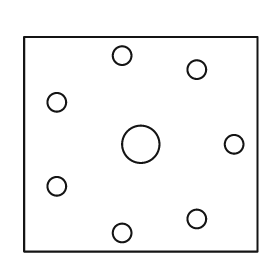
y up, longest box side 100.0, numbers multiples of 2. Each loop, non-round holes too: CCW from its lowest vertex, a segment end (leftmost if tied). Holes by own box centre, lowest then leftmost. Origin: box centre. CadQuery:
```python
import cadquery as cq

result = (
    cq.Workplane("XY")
    .moveTo(-50.0, -46.0)
    .lineTo(50.0, -46.0)
    .lineTo(50.0, 46.0)
    .lineTo(-50.0, 46.0)
    .close()
    .moveTo(-8.0, -38.0)
    .circle(4.0)
    .moveTo(24.0, -32.0)
    .circle(4.0)
    .moveTo(-36.0, -18.0)
    .circle(4.0)
    .moveTo(0.0, 0.0)
    .circle(8.0)
    .moveTo(40.0, 0.0)
    .circle(4.0)
    .moveTo(-36.0, 18.0)
    .circle(4.0)
    .moveTo(24.0, 32.0)
    .circle(4.0)
    .moveTo(-8.0, 38.0)
    .circle(4.0)
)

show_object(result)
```